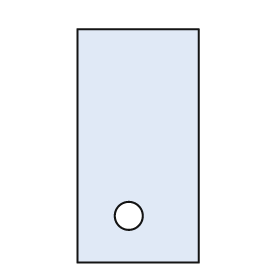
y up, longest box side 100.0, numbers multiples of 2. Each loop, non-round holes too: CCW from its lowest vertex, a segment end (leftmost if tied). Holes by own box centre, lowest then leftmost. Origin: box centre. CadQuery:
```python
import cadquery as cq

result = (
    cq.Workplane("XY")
    .moveTo(-26.0, -50.0)
    .lineTo(26.0, -50.0)
    .lineTo(26.0, 50.0)
    .lineTo(-26.0, 50.0)
    .close()
    .moveTo(-4.0, -30.0)
    .circle(6.0)
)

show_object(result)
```